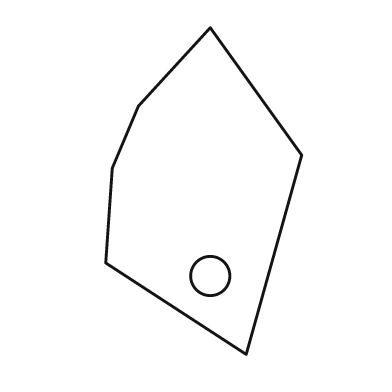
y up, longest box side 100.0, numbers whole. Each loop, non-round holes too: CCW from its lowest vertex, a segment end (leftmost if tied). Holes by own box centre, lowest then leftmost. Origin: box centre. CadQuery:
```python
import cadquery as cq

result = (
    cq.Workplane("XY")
    .moveTo(13.0, -50.0)
    .lineTo(30.0, 11.0)
    .lineTo(2.0, 50.0)
    .lineTo(-20.0, 26.0)
    .lineTo(-28.0, 7.0)
    .lineTo(-30.0, -22.0)
    .close()
    .moveTo(2.0, -26.0)
    .circle(6.0)
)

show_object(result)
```